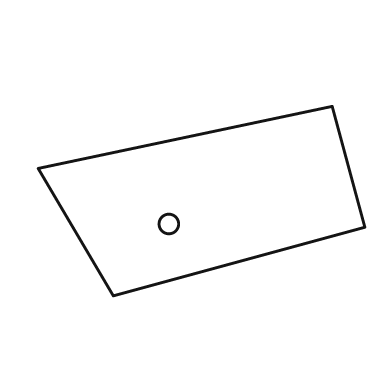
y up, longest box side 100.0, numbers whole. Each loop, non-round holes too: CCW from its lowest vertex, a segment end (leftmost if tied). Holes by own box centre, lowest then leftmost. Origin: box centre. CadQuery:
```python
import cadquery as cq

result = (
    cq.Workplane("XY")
    .moveTo(-27.0, -29.0)
    .lineTo(50.0, -8.0)
    .lineTo(40.0, 29.0)
    .lineTo(-50.0, 10.0)
    .close()
    .moveTo(-10.0, -7.0)
    .circle(3.0)
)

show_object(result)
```